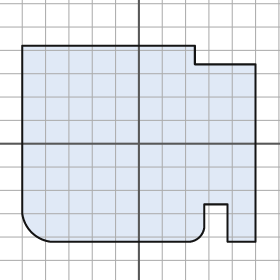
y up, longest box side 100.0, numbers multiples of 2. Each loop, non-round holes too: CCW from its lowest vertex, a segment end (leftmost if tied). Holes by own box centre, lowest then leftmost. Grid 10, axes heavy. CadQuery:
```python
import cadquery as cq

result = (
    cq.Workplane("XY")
    .moveTo(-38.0, -42.0)
    .lineTo(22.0, -42.0)
    .threePointArc((26.0, -40.0), (28.0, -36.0))
    .lineTo(28.0, -26.0)
    .lineTo(38.0, -26.0)
    .lineTo(38.0, -42.0)
    .lineTo(50.0, -42.0)
    .lineTo(50.0, 34.0)
    .lineTo(24.0, 34.0)
    .lineTo(24.0, 42.0)
    .lineTo(-50.0, 42.0)
    .lineTo(-50.0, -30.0)
    .threePointArc((-46.0, -38.0), (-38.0, -42.0))
    .close()
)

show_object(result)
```